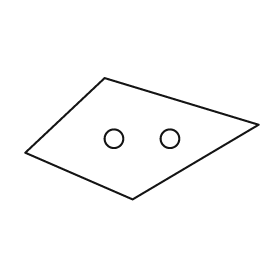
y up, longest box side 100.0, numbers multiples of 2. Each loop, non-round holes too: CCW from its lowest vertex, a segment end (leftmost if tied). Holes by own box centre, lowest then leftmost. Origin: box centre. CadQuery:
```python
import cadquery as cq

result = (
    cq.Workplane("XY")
    .moveTo(-4.0, -26.0)
    .lineTo(50.0, 6.0)
    .lineTo(-16.0, 26.0)
    .lineTo(-50.0, -6.0)
    .close()
    .moveTo(-12.0, 0.0)
    .circle(4.0)
    .moveTo(12.0, 0.0)
    .circle(4.0)
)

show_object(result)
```